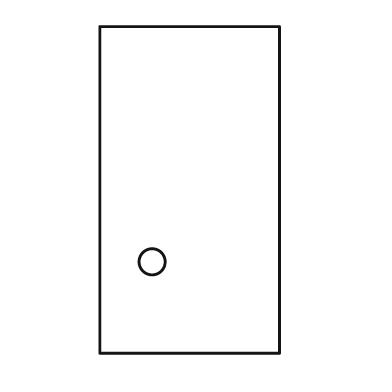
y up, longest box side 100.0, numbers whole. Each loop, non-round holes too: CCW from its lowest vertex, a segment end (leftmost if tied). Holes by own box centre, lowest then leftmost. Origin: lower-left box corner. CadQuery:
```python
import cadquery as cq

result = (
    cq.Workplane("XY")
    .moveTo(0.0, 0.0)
    .lineTo(55.0, 0.0)
    .lineTo(55.0, 100.0)
    .lineTo(0.0, 100.0)
    .close()
    .moveTo(16.0, 28.0)
    .circle(4.0)
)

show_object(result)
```